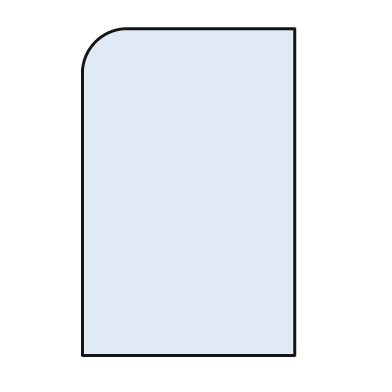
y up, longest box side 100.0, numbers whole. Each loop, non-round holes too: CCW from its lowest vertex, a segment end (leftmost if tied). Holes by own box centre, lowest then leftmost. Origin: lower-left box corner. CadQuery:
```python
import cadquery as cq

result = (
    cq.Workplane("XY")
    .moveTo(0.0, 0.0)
    .lineTo(65.0, 0.0)
    .lineTo(65.0, 100.0)
    .lineTo(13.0, 100.0)
    .threePointArc((4.0, 96.0), (0.0, 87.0))
    .close()
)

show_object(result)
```